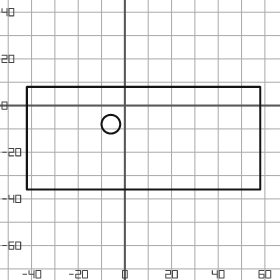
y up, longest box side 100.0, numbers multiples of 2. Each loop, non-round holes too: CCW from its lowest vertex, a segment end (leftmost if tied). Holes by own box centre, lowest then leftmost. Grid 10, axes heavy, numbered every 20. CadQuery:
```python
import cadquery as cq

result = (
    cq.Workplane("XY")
    .moveTo(-42.0, -36.0)
    .lineTo(58.0, -36.0)
    .lineTo(58.0, 8.0)
    .lineTo(-42.0, 8.0)
    .close()
    .moveTo(-6.0, -8.0)
    .circle(4.0)
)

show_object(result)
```